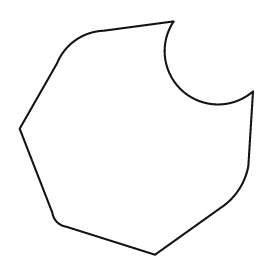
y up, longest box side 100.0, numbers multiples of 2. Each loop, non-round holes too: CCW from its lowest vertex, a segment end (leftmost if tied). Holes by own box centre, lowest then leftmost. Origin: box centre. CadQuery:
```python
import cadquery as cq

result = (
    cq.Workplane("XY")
    .moveTo(8.0, -50.0)
    .lineTo(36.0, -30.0)
    .threePointArc((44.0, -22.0), (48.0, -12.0))
    .lineTo(50.0, 20.0)
    .threePointArc((20.0, 20.0), (16.0, 50.0))
    .lineTo(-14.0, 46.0)
    .threePointArc((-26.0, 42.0), (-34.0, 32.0))
    .lineTo(-50.0, 4.0)
    .lineTo(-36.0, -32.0)
    .threePointArc((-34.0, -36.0), (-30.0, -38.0))
    .close()
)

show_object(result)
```